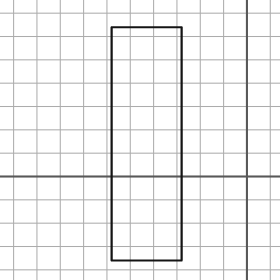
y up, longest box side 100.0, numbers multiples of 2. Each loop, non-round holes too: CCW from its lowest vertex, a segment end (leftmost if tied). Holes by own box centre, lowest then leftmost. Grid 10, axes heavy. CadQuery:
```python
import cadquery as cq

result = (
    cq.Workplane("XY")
    .moveTo(-58.0, -36.0)
    .lineTo(-28.0, -36.0)
    .lineTo(-28.0, 64.0)
    .lineTo(-58.0, 64.0)
    .close()
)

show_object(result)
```